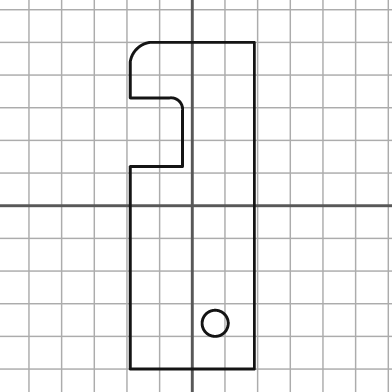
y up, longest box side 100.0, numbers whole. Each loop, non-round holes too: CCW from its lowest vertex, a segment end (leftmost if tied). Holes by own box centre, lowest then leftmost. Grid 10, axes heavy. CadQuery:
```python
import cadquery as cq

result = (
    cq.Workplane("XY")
    .moveTo(-19.0, -50.0)
    .lineTo(19.0, -50.0)
    .lineTo(19.0, 50.0)
    .lineTo(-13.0, 50.0)
    .threePointArc((-17.0, 48.0), (-19.0, 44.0))
    .lineTo(-19.0, 33.0)
    .lineTo(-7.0, 33.0)
    .threePointArc((-4.0, 32.0), (-3.0, 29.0))
    .lineTo(-3.0, 12.0)
    .lineTo(-19.0, 12.0)
    .close()
    .moveTo(7.0, -36.0)
    .circle(4.0)
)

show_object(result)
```